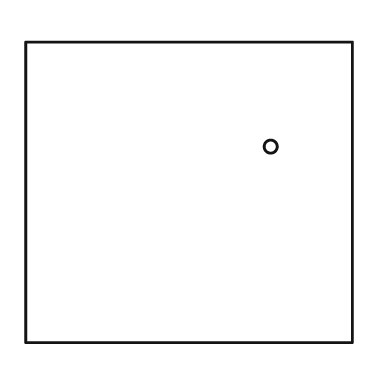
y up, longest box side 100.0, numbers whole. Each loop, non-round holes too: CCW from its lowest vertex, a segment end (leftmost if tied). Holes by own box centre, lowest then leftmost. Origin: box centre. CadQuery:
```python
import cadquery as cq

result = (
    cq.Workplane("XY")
    .moveTo(-50.0, -46.0)
    .lineTo(50.0, -46.0)
    .lineTo(50.0, 46.0)
    .lineTo(-50.0, 46.0)
    .close()
    .moveTo(25.0, 14.0)
    .circle(2.0)
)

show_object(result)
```